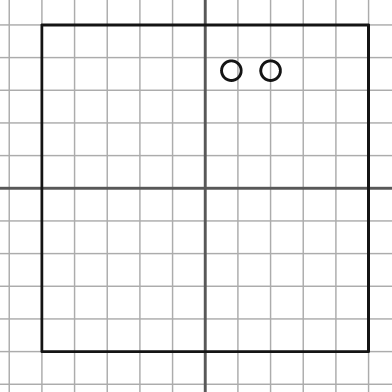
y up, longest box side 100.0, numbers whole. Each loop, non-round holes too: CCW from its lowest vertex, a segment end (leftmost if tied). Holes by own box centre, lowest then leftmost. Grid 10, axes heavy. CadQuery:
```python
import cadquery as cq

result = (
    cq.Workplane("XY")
    .moveTo(-50.0, -50.0)
    .lineTo(50.0, -50.0)
    .lineTo(50.0, 50.0)
    .lineTo(-50.0, 50.0)
    .close()
    .moveTo(8.0, 36.0)
    .circle(3.0)
    .moveTo(20.0, 36.0)
    .circle(3.0)
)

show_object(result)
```